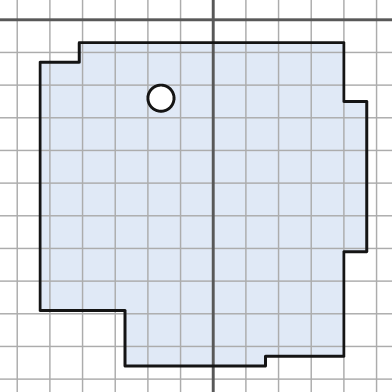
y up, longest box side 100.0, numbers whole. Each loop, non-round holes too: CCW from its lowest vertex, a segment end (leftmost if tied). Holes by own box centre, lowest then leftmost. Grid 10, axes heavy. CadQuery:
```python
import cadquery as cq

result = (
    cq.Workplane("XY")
    .moveTo(-27.0, -106.0)
    .lineTo(16.0, -106.0)
    .lineTo(16.0, -103.0)
    .lineTo(40.0, -103.0)
    .lineTo(40.0, -71.0)
    .lineTo(47.0, -71.0)
    .lineTo(47.0, -25.0)
    .lineTo(40.0, -25.0)
    .lineTo(40.0, -7.0)
    .lineTo(-41.0, -7.0)
    .lineTo(-41.0, -13.0)
    .lineTo(-53.0, -13.0)
    .lineTo(-53.0, -89.0)
    .lineTo(-27.0, -89.0)
    .close()
    .moveTo(-16.0, -24.0)
    .circle(4.0)
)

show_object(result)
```